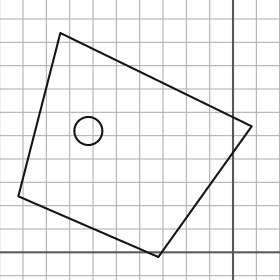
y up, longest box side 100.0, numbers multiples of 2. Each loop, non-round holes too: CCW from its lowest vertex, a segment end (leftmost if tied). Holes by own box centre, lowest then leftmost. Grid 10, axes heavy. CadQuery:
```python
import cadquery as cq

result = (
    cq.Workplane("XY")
    .moveTo(-32.0, -2.0)
    .lineTo(8.0, 54.0)
    .lineTo(-74.0, 94.0)
    .lineTo(-92.0, 24.0)
    .close()
    .moveTo(-62.0, 52.0)
    .circle(6.0)
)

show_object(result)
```